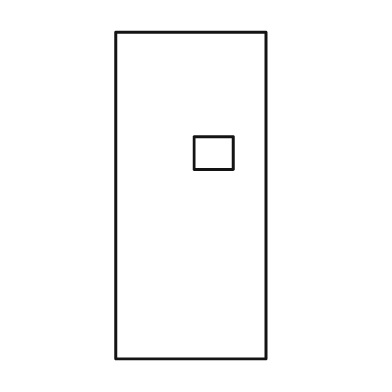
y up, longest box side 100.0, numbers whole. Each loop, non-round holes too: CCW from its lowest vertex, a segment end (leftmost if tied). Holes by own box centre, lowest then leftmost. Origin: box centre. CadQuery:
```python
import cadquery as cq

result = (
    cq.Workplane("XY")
    .moveTo(-23.0, -50.0)
    .lineTo(23.0, -50.0)
    .lineTo(23.0, 50.0)
    .lineTo(-23.0, 50.0)
    .close()
    .moveTo(1.0, 8.0)
    .lineTo(13.0, 8.0)
    .lineTo(13.0, 18.0)
    .lineTo(1.0, 18.0)
    .close()
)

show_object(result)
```